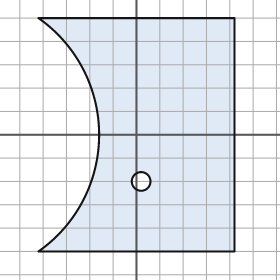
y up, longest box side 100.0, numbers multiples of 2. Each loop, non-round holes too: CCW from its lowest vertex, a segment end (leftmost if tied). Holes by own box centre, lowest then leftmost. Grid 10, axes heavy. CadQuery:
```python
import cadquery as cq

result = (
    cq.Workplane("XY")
    .moveTo(-42.0, -50.0)
    .lineTo(42.0, -50.0)
    .lineTo(42.0, 50.0)
    .lineTo(-42.0, 50.0)
    .threePointArc((-16.0, 0.0), (-42.0, -50.0))
    .close()
    .moveTo(2.0, -20.0)
    .circle(4.0)
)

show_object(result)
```